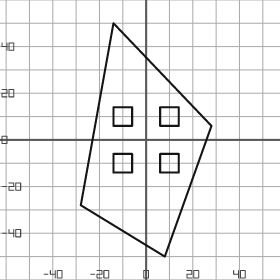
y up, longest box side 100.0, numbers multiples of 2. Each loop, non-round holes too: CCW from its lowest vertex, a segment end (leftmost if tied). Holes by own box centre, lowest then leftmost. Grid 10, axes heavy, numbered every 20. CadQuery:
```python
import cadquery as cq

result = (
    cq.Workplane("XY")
    .moveTo(8.0, -50.0)
    .lineTo(28.0, 6.0)
    .lineTo(-14.0, 50.0)
    .lineTo(-28.0, -28.0)
    .close()
    .moveTo(-14.0, -14.0)
    .lineTo(-6.0, -14.0)
    .lineTo(-6.0, -6.0)
    .lineTo(-14.0, -6.0)
    .close()
    .moveTo(6.0, -14.0)
    .lineTo(14.0, -14.0)
    .lineTo(14.0, -6.0)
    .lineTo(6.0, -6.0)
    .close()
    .moveTo(-14.0, 6.0)
    .lineTo(-6.0, 6.0)
    .lineTo(-6.0, 14.0)
    .lineTo(-14.0, 14.0)
    .close()
    .moveTo(6.0, 6.0)
    .lineTo(14.0, 6.0)
    .lineTo(14.0, 14.0)
    .lineTo(6.0, 14.0)
    .close()
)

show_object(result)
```